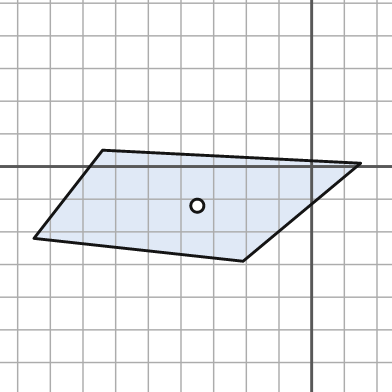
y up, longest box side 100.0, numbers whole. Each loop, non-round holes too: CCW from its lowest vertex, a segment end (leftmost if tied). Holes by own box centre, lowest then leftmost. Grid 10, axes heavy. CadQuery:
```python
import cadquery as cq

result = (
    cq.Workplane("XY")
    .moveTo(-21.0, -29.0)
    .lineTo(15.0, 1.0)
    .lineTo(-64.0, 5.0)
    .lineTo(-85.0, -22.0)
    .close()
    .moveTo(-35.0, -12.0)
    .circle(2.0)
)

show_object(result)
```